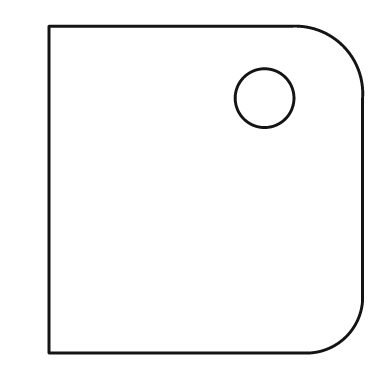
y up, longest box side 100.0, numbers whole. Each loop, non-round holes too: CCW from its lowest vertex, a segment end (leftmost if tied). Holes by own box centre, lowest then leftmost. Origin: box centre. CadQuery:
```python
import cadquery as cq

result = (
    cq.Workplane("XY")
    .moveTo(-48.0, -50.0)
    .lineTo(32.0, -50.0)
    .threePointArc((43.0, -45.0), (48.0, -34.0))
    .lineTo(48.0, 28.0)
    .threePointArc((42.0, 44.0), (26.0, 50.0))
    .lineTo(-48.0, 50.0)
    .close()
    .moveTo(18.0, 28.0)
    .circle(9.0)
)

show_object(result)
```